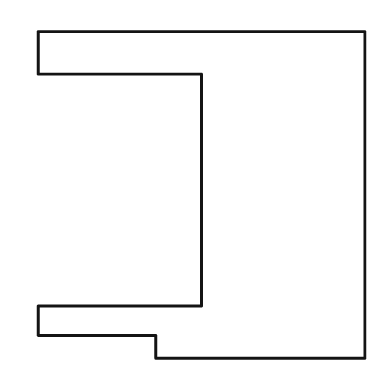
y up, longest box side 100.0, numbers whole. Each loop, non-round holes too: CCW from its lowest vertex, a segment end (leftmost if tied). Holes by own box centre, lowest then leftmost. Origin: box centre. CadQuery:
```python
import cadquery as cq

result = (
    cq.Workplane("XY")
    .moveTo(-14.0, -50.0)
    .lineTo(50.0, -50.0)
    .lineTo(50.0, 50.0)
    .lineTo(-50.0, 50.0)
    .lineTo(-50.0, 37.0)
    .lineTo(0.0, 37.0)
    .lineTo(0.0, -34.0)
    .lineTo(-50.0, -34.0)
    .lineTo(-50.0, -43.0)
    .lineTo(-14.0, -43.0)
    .close()
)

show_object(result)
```